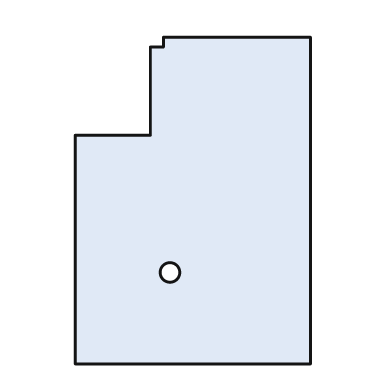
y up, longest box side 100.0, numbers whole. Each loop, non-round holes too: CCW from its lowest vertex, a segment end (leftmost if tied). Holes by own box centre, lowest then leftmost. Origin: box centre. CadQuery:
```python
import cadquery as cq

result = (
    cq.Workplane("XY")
    .moveTo(-36.0, -50.0)
    .lineTo(36.0, -50.0)
    .lineTo(36.0, 50.0)
    .lineTo(-9.0, 50.0)
    .lineTo(-9.0, 47.0)
    .lineTo(-13.0, 47.0)
    .lineTo(-13.0, 20.0)
    .lineTo(-36.0, 20.0)
    .close()
    .moveTo(-7.0, -22.0)
    .circle(3.0)
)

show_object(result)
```